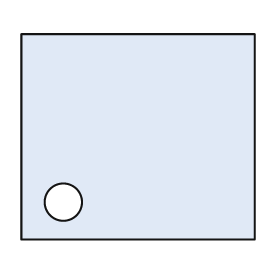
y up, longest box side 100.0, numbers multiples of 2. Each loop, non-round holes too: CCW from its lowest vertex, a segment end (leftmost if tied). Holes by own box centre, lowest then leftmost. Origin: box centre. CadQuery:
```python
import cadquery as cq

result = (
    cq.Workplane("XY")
    .moveTo(-50.0, -44.0)
    .lineTo(50.0, -44.0)
    .lineTo(50.0, 44.0)
    .lineTo(-50.0, 44.0)
    .close()
    .moveTo(-32.0, -28.0)
    .circle(8.0)
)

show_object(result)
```